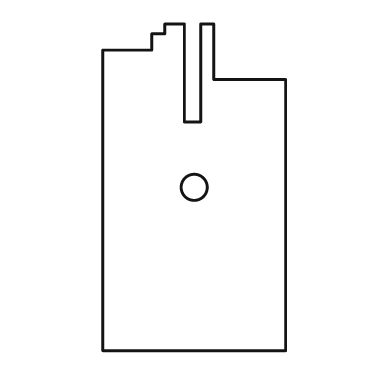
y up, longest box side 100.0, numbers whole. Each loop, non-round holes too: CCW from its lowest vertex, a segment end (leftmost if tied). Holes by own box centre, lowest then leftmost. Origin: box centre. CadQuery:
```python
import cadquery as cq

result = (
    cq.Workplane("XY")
    .moveTo(-28.0, -50.0)
    .lineTo(28.0, -50.0)
    .lineTo(28.0, 33.0)
    .lineTo(6.0, 33.0)
    .lineTo(6.0, 50.0)
    .lineTo(2.0, 50.0)
    .lineTo(2.0, 20.0)
    .lineTo(-3.0, 20.0)
    .lineTo(-3.0, 50.0)
    .lineTo(-9.0, 50.0)
    .lineTo(-9.0, 47.0)
    .lineTo(-13.0, 47.0)
    .lineTo(-13.0, 42.0)
    .lineTo(-28.0, 42.0)
    .close()
    .moveTo(0.0, 0.0)
    .circle(4.0)
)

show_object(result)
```